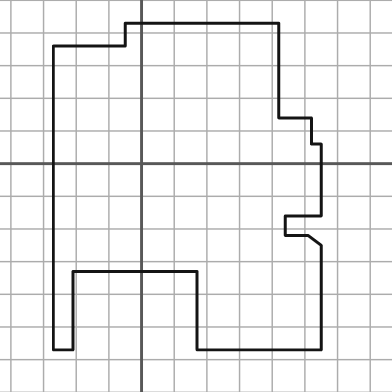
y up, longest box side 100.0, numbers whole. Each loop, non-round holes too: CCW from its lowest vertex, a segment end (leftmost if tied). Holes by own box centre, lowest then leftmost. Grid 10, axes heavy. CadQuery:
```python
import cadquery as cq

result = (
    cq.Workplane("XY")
    .moveTo(-27.0, -57.0)
    .lineTo(-21.0, -57.0)
    .lineTo(-21.0, -33.0)
    .lineTo(17.0, -33.0)
    .lineTo(17.0, -57.0)
    .lineTo(55.0, -57.0)
    .lineTo(55.0, -25.0)
    .lineTo(51.0, -22.0)
    .lineTo(44.0, -22.0)
    .lineTo(44.0, -16.0)
    .lineTo(55.0, -16.0)
    .lineTo(55.0, 6.0)
    .lineTo(52.0, 6.0)
    .lineTo(52.0, 14.0)
    .lineTo(42.0, 14.0)
    .lineTo(42.0, 43.0)
    .lineTo(-5.0, 43.0)
    .lineTo(-5.0, 36.0)
    .lineTo(-27.0, 36.0)
    .close()
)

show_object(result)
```